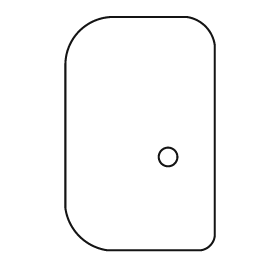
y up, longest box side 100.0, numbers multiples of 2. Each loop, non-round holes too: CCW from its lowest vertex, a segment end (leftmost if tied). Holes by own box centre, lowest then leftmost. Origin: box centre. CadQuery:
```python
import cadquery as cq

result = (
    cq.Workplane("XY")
    .moveTo(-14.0, -50.0)
    .lineTo(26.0, -50.0)
    .threePointArc((30.0, -48.0), (32.0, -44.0))
    .lineTo(32.0, 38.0)
    .threePointArc((28.0, 46.0), (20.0, 50.0))
    .lineTo(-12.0, 50.0)
    .threePointArc((-26.0, 44.0), (-32.0, 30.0))
    .lineTo(-32.0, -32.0)
    .threePointArc((-26.0, -44.0), (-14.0, -50.0))
    .close()
    .moveTo(12.0, -10.0)
    .circle(4.0)
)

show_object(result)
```